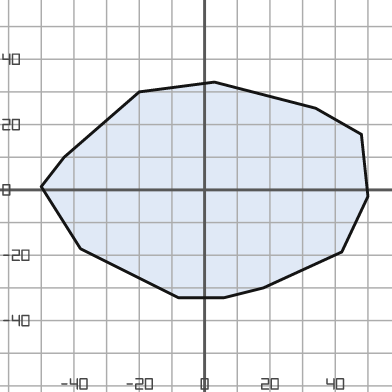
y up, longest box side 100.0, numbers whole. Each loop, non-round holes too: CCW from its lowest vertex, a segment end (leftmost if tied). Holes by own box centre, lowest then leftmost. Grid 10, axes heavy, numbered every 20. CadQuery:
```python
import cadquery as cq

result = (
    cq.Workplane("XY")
    .moveTo(-8.0, -33.0)
    .lineTo(6.0, -33.0)
    .lineTo(18.0, -30.0)
    .lineTo(42.0, -19.0)
    .lineTo(50.0, -2.0)
    .lineTo(48.0, 17.0)
    .lineTo(34.0, 25.0)
    .lineTo(3.0, 33.0)
    .lineTo(-20.0, 30.0)
    .lineTo(-43.0, 10.0)
    .lineTo(-50.0, 1.0)
    .lineTo(-38.0, -18.0)
    .close()
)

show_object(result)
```